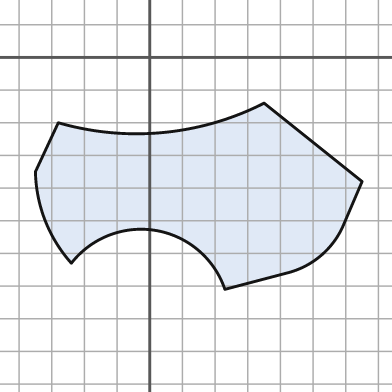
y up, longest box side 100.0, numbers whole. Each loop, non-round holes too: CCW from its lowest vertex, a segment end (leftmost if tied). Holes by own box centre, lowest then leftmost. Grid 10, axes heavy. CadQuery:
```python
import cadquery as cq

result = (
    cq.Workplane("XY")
    .moveTo(23.0, -71.0)
    .lineTo(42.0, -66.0)
    .threePointArc((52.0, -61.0), (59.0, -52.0))
    .lineTo(65.0, -38.0)
    .lineTo(35.0, -14.0)
    .threePointArc((4.0, -23.0), (-28.0, -20.0))
    .lineTo(-35.0, -35.0)
    .threePointArc((-32.0, -50.0), (-24.0, -63.0))
    .threePointArc((2.0, -53.0), (23.0, -71.0))
    .close()
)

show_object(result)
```